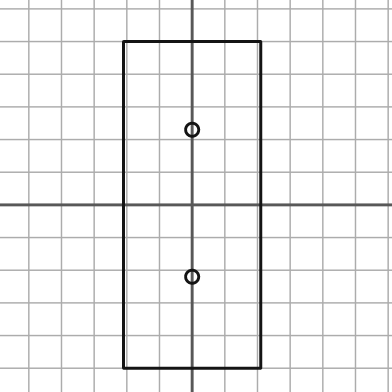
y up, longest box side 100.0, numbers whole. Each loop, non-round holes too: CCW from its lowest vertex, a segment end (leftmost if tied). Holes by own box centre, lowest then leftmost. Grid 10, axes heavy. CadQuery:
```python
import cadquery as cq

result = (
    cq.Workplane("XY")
    .moveTo(-21.0, -50.0)
    .lineTo(21.0, -50.0)
    .lineTo(21.0, 50.0)
    .lineTo(-21.0, 50.0)
    .close()
    .moveTo(0.0, -22.0)
    .circle(2.0)
    .moveTo(0.0, 23.0)
    .circle(2.0)
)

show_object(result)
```